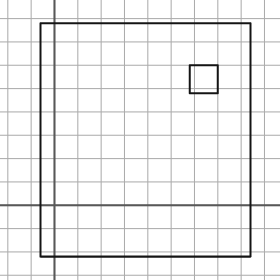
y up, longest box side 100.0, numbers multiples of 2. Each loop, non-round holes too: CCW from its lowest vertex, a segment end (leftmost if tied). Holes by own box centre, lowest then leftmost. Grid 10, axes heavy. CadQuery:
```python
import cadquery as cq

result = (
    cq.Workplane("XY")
    .moveTo(-6.0, -22.0)
    .lineTo(84.0, -22.0)
    .lineTo(84.0, 78.0)
    .lineTo(-6.0, 78.0)
    .close()
    .moveTo(58.0, 48.0)
    .lineTo(70.0, 48.0)
    .lineTo(70.0, 60.0)
    .lineTo(58.0, 60.0)
    .close()
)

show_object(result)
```